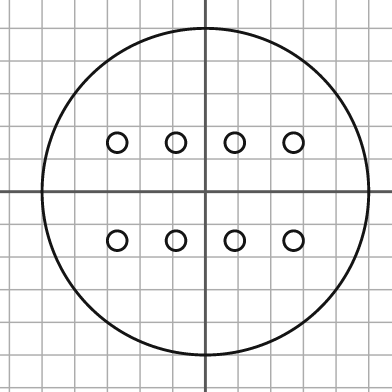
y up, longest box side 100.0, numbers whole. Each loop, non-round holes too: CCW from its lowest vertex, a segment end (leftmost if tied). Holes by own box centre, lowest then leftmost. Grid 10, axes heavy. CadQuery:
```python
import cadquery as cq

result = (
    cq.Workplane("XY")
    .moveTo(0.0, 0.0)
    .circle(50.0)
    .moveTo(-27.0, -15.0)
    .circle(3.0)
    .moveTo(-9.0, -15.0)
    .circle(3.0)
    .moveTo(9.0, -15.0)
    .circle(3.0)
    .moveTo(27.0, -15.0)
    .circle(3.0)
    .moveTo(-27.0, 15.0)
    .circle(3.0)
    .moveTo(-9.0, 15.0)
    .circle(3.0)
    .moveTo(9.0, 15.0)
    .circle(3.0)
    .moveTo(27.0, 15.0)
    .circle(3.0)
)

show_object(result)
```